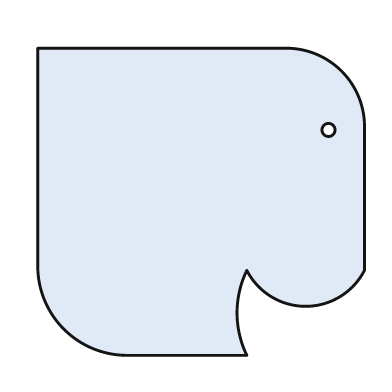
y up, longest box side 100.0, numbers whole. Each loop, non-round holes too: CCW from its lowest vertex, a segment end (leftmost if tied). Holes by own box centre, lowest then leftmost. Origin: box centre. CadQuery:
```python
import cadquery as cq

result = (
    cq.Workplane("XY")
    .moveTo(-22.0, -47.0)
    .lineTo(14.0, -47.0)
    .threePointArc((11.0, -34.0), (14.0, -21.0))
    .threePointArc((32.0, -32.0), (50.0, -21.0))
    .lineTo(50.0, 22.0)
    .threePointArc((43.0, 40.0), (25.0, 47.0))
    .lineTo(-50.0, 47.0)
    .lineTo(-50.0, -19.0)
    .threePointArc((-42.0, -39.0), (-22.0, -47.0))
    .close()
    .moveTo(39.0, 22.0)
    .circle(2.0)
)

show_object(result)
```